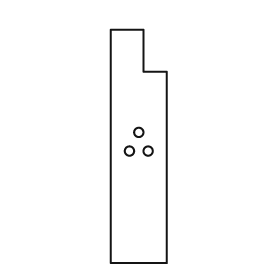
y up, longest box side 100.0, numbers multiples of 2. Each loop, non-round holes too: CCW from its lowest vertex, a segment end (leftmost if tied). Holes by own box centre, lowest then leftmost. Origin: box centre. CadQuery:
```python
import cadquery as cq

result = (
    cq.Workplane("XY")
    .moveTo(-12.0, -50.0)
    .lineTo(12.0, -50.0)
    .lineTo(12.0, 32.0)
    .lineTo(2.0, 32.0)
    .lineTo(2.0, 50.0)
    .lineTo(-12.0, 50.0)
    .close()
    .moveTo(-4.0, -2.0)
    .circle(2.0)
    .moveTo(4.0, -2.0)
    .circle(2.0)
    .moveTo(0.0, 6.0)
    .circle(2.0)
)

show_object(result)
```